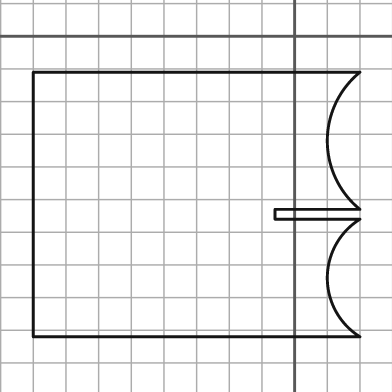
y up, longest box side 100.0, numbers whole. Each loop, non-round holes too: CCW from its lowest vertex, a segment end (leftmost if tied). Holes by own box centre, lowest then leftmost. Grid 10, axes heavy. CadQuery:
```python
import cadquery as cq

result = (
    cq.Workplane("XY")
    .moveTo(-80.0, -92.0)
    .lineTo(20.0, -92.0)
    .threePointArc((10.0, -74.0), (20.0, -56.0))
    .lineTo(-6.0, -56.0)
    .lineTo(-6.0, -53.0)
    .lineTo(20.0, -53.0)
    .threePointArc((10.0, -32.0), (20.0, -11.0))
    .lineTo(-80.0, -11.0)
    .close()
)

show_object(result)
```